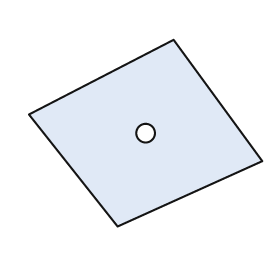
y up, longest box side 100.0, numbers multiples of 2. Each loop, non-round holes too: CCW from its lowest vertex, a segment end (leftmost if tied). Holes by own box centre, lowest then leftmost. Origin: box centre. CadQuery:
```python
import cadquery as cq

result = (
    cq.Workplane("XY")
    .moveTo(-12.0, -40.0)
    .lineTo(50.0, -12.0)
    .lineTo(12.0, 40.0)
    .lineTo(-50.0, 8.0)
    .close()
    .moveTo(0.0, 0.0)
    .circle(4.0)
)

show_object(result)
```